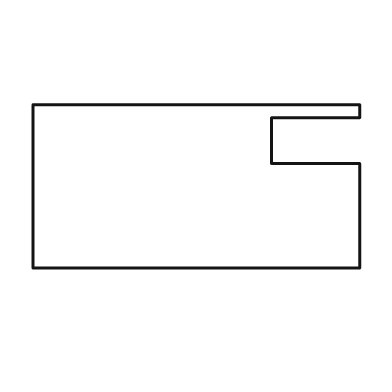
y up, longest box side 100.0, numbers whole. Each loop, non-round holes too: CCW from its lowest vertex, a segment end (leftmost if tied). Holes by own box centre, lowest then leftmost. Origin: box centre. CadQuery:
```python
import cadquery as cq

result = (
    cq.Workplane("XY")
    .moveTo(-50.0, -25.0)
    .lineTo(50.0, -25.0)
    .lineTo(50.0, 7.0)
    .lineTo(23.0, 7.0)
    .lineTo(23.0, 21.0)
    .lineTo(50.0, 21.0)
    .lineTo(50.0, 25.0)
    .lineTo(-50.0, 25.0)
    .close()
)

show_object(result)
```